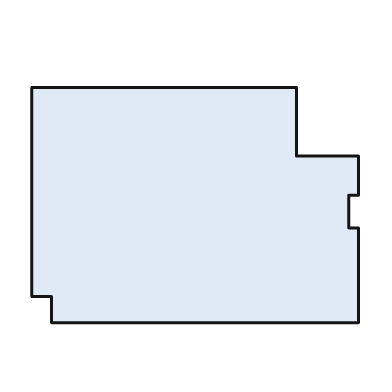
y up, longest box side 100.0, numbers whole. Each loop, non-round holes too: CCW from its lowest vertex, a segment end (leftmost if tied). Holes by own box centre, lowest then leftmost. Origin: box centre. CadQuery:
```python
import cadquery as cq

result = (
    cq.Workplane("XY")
    .moveTo(-44.0, -36.0)
    .lineTo(50.0, -36.0)
    .lineTo(50.0, -7.0)
    .lineTo(47.0, -7.0)
    .lineTo(47.0, 3.0)
    .lineTo(50.0, 3.0)
    .lineTo(50.0, 15.0)
    .lineTo(31.0, 15.0)
    .lineTo(31.0, 36.0)
    .lineTo(-50.0, 36.0)
    .lineTo(-50.0, -28.0)
    .lineTo(-44.0, -28.0)
    .close()
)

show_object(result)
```